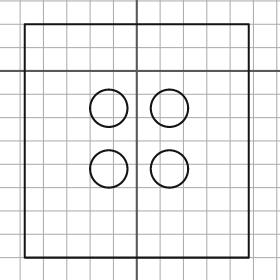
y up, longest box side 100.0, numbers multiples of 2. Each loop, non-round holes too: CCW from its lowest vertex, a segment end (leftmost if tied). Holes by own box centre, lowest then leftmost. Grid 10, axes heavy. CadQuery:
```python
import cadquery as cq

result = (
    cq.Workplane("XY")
    .moveTo(-48.0, -80.0)
    .lineTo(48.0, -80.0)
    .lineTo(48.0, 20.0)
    .lineTo(-48.0, 20.0)
    .close()
    .moveTo(-12.0, -42.0)
    .circle(8.0)
    .moveTo(14.0, -42.0)
    .circle(8.0)
    .moveTo(-12.0, -16.0)
    .circle(8.0)
    .moveTo(14.0, -16.0)
    .circle(8.0)
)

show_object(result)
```